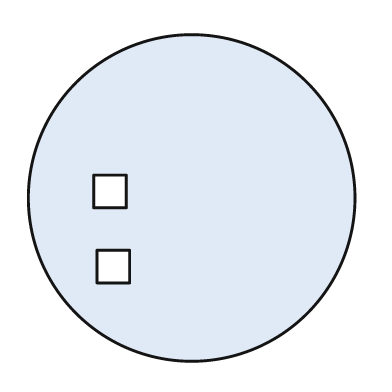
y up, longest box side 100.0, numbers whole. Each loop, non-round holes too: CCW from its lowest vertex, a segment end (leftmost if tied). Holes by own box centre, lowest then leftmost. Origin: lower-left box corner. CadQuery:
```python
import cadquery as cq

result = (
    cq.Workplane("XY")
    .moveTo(50.0, 50.0)
    .circle(50.0)
    .moveTo(21.0, 24.0)
    .lineTo(31.0, 24.0)
    .lineTo(31.0, 34.0)
    .lineTo(21.0, 34.0)
    .close()
    .moveTo(20.0, 47.0)
    .lineTo(30.0, 47.0)
    .lineTo(30.0, 57.0)
    .lineTo(20.0, 57.0)
    .close()
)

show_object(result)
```